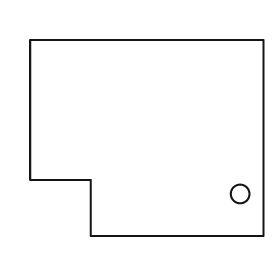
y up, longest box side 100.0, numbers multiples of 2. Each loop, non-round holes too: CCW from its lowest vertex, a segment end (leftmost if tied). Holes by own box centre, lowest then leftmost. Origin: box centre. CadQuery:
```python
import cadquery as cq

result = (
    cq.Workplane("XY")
    .moveTo(-24.0, -42.0)
    .lineTo(50.0, -42.0)
    .lineTo(50.0, 42.0)
    .lineTo(-50.0, 42.0)
    .lineTo(-50.0, -18.0)
    .lineTo(-24.0, -18.0)
    .close()
    .moveTo(40.0, -24.0)
    .circle(4.0)
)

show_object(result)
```